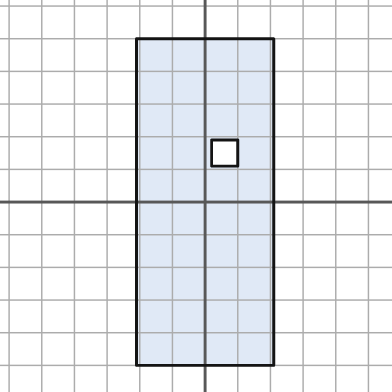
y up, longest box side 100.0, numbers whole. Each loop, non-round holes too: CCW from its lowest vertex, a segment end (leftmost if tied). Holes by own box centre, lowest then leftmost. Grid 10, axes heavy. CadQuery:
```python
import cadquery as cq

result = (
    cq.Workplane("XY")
    .moveTo(-21.0, -50.0)
    .lineTo(21.0, -50.0)
    .lineTo(21.0, 50.0)
    .lineTo(-21.0, 50.0)
    .close()
    .moveTo(2.0, 11.0)
    .lineTo(10.0, 11.0)
    .lineTo(10.0, 19.0)
    .lineTo(2.0, 19.0)
    .close()
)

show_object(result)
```